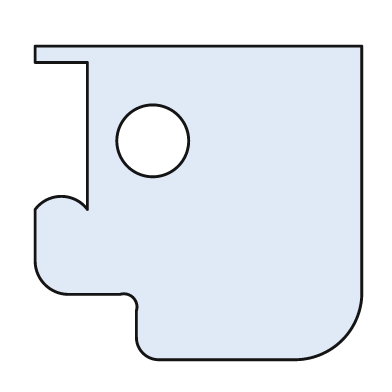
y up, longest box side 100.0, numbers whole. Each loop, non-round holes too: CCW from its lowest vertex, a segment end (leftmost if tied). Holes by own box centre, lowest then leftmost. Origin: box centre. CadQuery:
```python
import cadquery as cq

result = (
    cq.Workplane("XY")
    .moveTo(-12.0, -48.0)
    .lineTo(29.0, -48.0)
    .threePointArc((44.0, -42.0), (50.0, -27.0))
    .lineTo(50.0, 48.0)
    .lineTo(-50.0, 48.0)
    .lineTo(-50.0, 43.0)
    .lineTo(-34.0, 43.0)
    .lineTo(-34.0, -2.0)
    .threePointArc((-42.0, 2.0), (-50.0, -2.0))
    .lineTo(-50.0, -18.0)
    .threePointArc((-47.0, -25.0), (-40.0, -28.0))
    .lineTo(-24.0, -28.0)
    .threePointArc((-20.0, -29.0), (-19.0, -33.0))
    .lineTo(-19.0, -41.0)
    .threePointArc((-17.0, -46.0), (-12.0, -48.0))
    .close()
    .moveTo(-14.0, 19.0)
    .circle(11.0)
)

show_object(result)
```